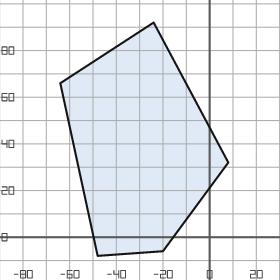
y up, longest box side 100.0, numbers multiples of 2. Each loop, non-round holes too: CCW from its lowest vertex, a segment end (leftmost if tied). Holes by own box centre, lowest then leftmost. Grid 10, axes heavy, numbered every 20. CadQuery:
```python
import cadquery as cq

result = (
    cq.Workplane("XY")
    .moveTo(-48.0, -8.0)
    .lineTo(-20.0, -6.0)
    .lineTo(8.0, 32.0)
    .lineTo(-24.0, 92.0)
    .lineTo(-64.0, 66.0)
    .close()
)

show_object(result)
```